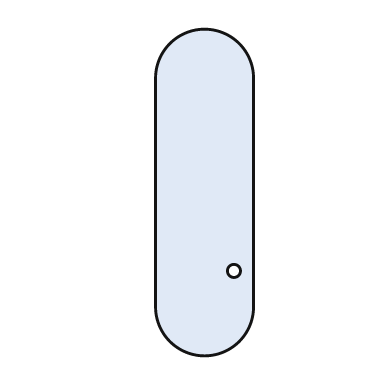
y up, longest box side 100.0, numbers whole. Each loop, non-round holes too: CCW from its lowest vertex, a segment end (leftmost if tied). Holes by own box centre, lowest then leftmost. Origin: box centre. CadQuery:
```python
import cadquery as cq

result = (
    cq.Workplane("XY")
    .moveTo(-15.0, -35.0)
    .threePointArc((0.0, -50.0), (15.0, -35.0))
    .lineTo(15.0, 35.0)
    .threePointArc((0.0, 50.0), (-15.0, 35.0))
    .close()
    .moveTo(9.0, -24.0)
    .circle(2.0)
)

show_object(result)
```